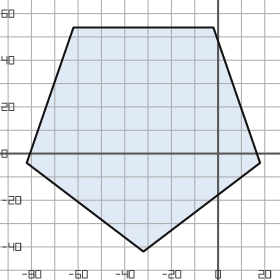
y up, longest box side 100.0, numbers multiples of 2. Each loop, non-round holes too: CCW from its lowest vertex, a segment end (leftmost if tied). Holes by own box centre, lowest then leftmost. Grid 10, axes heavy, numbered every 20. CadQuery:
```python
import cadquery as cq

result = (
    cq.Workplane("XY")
    .moveTo(-32.0, -42.0)
    .lineTo(18.0, -4.0)
    .lineTo(-2.0, 54.0)
    .lineTo(-62.0, 54.0)
    .lineTo(-82.0, -4.0)
    .close()
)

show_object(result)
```